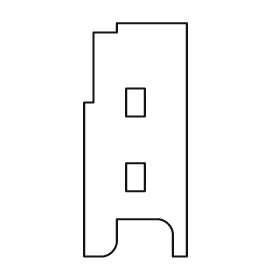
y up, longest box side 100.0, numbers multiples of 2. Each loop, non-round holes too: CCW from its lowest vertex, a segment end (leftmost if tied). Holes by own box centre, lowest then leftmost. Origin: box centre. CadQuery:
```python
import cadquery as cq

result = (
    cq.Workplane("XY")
    .moveTo(-22.0, -50.0)
    .lineTo(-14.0, -50.0)
    .threePointArc((-10.0, -48.0), (-8.0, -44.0))
    .lineTo(-8.0, -34.0)
    .lineTo(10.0, -34.0)
    .threePointArc((14.0, -36.0), (16.0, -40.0))
    .lineTo(16.0, -50.0)
    .lineTo(22.0, -50.0)
    .lineTo(22.0, 50.0)
    .lineTo(-8.0, 50.0)
    .lineTo(-8.0, 46.0)
    .lineTo(-18.0, 46.0)
    .lineTo(-18.0, 16.0)
    .lineTo(-22.0, 16.0)
    .close()
    .moveTo(-4.0, -22.0)
    .lineTo(4.0, -22.0)
    .lineTo(4.0, -10.0)
    .lineTo(-4.0, -10.0)
    .close()
    .moveTo(-4.0, 10.0)
    .lineTo(4.0, 10.0)
    .lineTo(4.0, 22.0)
    .lineTo(-4.0, 22.0)
    .close()
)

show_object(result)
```